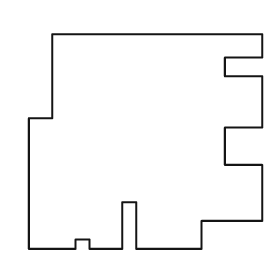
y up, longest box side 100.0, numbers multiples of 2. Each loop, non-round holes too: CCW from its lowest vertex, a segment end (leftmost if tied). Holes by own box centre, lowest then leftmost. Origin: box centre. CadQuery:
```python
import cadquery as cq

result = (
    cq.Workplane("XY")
    .moveTo(-50.0, -46.0)
    .lineTo(-30.0, -46.0)
    .lineTo(-30.0, -42.0)
    .lineTo(-24.0, -42.0)
    .lineTo(-24.0, -46.0)
    .lineTo(-10.0, -46.0)
    .lineTo(-10.0, -26.0)
    .lineTo(-4.0, -26.0)
    .lineTo(-4.0, -46.0)
    .lineTo(24.0, -46.0)
    .lineTo(24.0, -34.0)
    .lineTo(50.0, -34.0)
    .lineTo(50.0, -10.0)
    .lineTo(34.0, -10.0)
    .lineTo(34.0, 6.0)
    .lineTo(50.0, 6.0)
    .lineTo(50.0, 28.0)
    .lineTo(34.0, 28.0)
    .lineTo(34.0, 36.0)
    .lineTo(50.0, 36.0)
    .lineTo(50.0, 46.0)
    .lineTo(-40.0, 46.0)
    .lineTo(-40.0, 10.0)
    .lineTo(-50.0, 10.0)
    .close()
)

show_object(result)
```